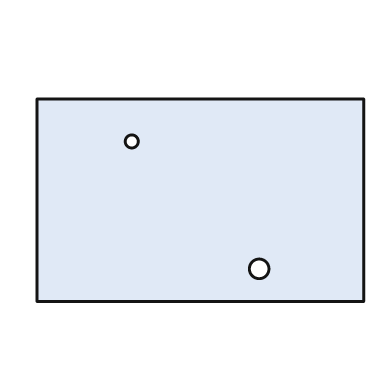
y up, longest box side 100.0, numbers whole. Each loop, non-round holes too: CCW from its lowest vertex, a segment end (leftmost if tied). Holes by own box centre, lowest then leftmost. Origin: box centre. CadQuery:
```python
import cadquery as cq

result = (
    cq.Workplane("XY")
    .moveTo(-50.0, -31.0)
    .lineTo(50.0, -31.0)
    .lineTo(50.0, 31.0)
    .lineTo(-50.0, 31.0)
    .close()
    .moveTo(18.0, -21.0)
    .circle(3.0)
    .moveTo(-21.0, 18.0)
    .circle(2.0)
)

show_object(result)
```